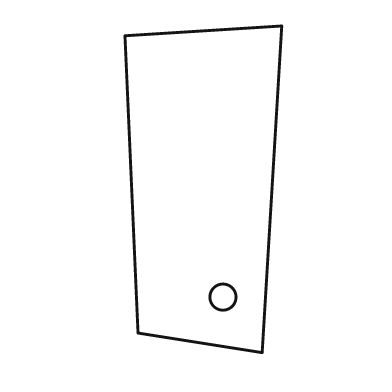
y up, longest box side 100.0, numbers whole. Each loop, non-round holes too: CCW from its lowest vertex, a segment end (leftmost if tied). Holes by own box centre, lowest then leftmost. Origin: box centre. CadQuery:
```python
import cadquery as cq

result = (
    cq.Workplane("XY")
    .moveTo(18.0, -50.0)
    .lineTo(24.0, 50.0)
    .lineTo(-24.0, 47.0)
    .lineTo(-20.0, -44.0)
    .close()
    .moveTo(6.0, -33.0)
    .circle(4.0)
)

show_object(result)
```